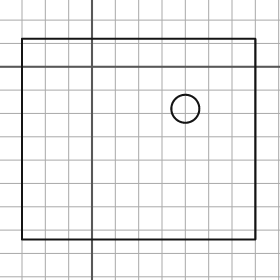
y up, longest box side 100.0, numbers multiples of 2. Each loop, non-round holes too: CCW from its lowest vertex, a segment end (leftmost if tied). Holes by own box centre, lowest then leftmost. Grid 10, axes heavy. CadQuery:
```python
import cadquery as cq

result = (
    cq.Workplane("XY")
    .moveTo(-30.0, -74.0)
    .lineTo(70.0, -74.0)
    .lineTo(70.0, 12.0)
    .lineTo(-30.0, 12.0)
    .close()
    .moveTo(40.0, -18.0)
    .circle(6.0)
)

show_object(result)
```